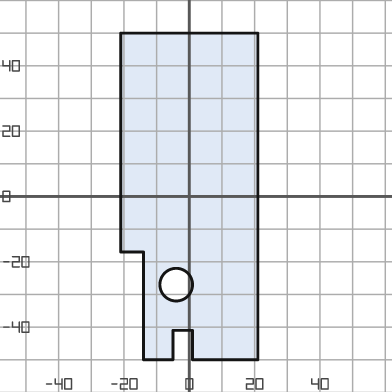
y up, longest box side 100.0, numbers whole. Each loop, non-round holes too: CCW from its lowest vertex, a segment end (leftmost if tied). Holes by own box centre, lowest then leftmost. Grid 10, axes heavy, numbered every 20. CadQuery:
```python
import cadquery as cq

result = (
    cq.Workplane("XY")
    .moveTo(-14.0, -50.0)
    .lineTo(-5.0, -50.0)
    .lineTo(-5.0, -41.0)
    .lineTo(1.0, -41.0)
    .lineTo(1.0, -50.0)
    .lineTo(21.0, -50.0)
    .lineTo(21.0, 50.0)
    .lineTo(-21.0, 50.0)
    .lineTo(-21.0, -17.0)
    .lineTo(-14.0, -17.0)
    .close()
    .moveTo(-4.0, -27.0)
    .circle(5.0)
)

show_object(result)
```